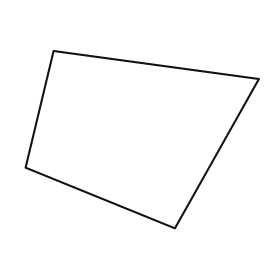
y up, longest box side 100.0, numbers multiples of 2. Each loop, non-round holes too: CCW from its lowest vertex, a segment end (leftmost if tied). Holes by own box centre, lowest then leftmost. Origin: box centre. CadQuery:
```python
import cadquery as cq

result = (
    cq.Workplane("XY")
    .moveTo(14.0, -38.0)
    .lineTo(50.0, 26.0)
    .lineTo(-38.0, 38.0)
    .lineTo(-50.0, -12.0)
    .close()
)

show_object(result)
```